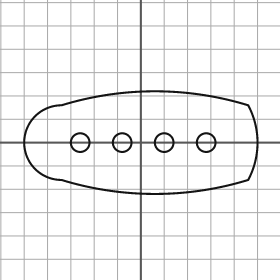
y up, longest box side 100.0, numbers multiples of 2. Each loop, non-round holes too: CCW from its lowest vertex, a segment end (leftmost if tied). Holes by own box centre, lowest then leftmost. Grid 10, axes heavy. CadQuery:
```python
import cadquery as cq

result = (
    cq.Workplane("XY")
    .moveTo(-34.0, -16.0)
    .threePointArc((6.0, -22.0), (46.0, -16.0))
    .threePointArc((50.0, 0.0), (46.0, 16.0))
    .threePointArc((6.0, 22.0), (-34.0, 16.0))
    .threePointArc((-50.0, 0.0), (-34.0, -16.0))
    .close()
    .moveTo(-26.0, 0.0)
    .circle(4.0)
    .moveTo(-8.0, 0.0)
    .circle(4.0)
    .moveTo(10.0, 0.0)
    .circle(4.0)
    .moveTo(28.0, 0.0)
    .circle(4.0)
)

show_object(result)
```